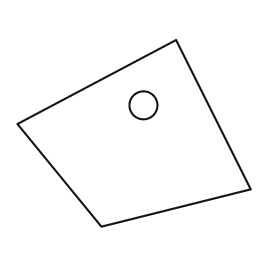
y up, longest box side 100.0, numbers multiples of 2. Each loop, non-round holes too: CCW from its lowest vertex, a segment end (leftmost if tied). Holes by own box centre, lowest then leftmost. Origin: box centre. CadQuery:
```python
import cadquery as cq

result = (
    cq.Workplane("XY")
    .moveTo(-14.0, -40.0)
    .lineTo(50.0, -24.0)
    .lineTo(18.0, 40.0)
    .lineTo(-50.0, 4.0)
    .close()
    .moveTo(4.0, 12.0)
    .circle(6.0)
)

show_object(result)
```